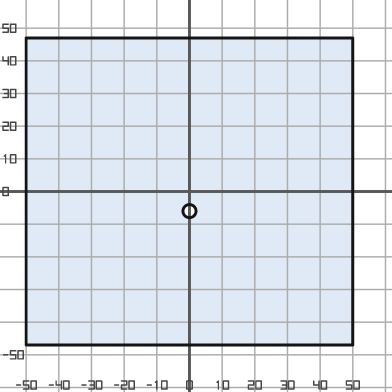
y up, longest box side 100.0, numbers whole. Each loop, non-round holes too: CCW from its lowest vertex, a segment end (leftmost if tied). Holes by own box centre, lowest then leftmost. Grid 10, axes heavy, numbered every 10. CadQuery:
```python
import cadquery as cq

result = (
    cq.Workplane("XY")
    .moveTo(-50.0, -47.0)
    .lineTo(50.0, -47.0)
    .lineTo(50.0, 47.0)
    .lineTo(-50.0, 47.0)
    .close()
    .moveTo(0.0, -6.0)
    .circle(2.0)
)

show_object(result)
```